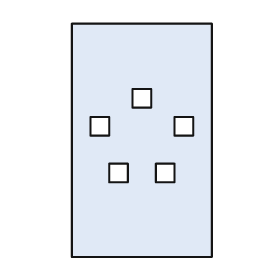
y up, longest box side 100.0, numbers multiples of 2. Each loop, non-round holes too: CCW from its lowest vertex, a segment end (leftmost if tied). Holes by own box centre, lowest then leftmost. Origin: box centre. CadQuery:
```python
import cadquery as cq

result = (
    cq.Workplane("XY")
    .moveTo(-30.0, -50.0)
    .lineTo(30.0, -50.0)
    .lineTo(30.0, 50.0)
    .lineTo(-30.0, 50.0)
    .close()
    .moveTo(-14.0, -18.0)
    .lineTo(-6.0, -18.0)
    .lineTo(-6.0, -10.0)
    .lineTo(-14.0, -10.0)
    .close()
    .moveTo(6.0, -18.0)
    .lineTo(14.0, -18.0)
    .lineTo(14.0, -10.0)
    .lineTo(6.0, -10.0)
    .close()
    .moveTo(-22.0, 2.0)
    .lineTo(-14.0, 2.0)
    .lineTo(-14.0, 10.0)
    .lineTo(-22.0, 10.0)
    .close()
    .moveTo(14.0, 2.0)
    .lineTo(22.0, 2.0)
    .lineTo(22.0, 10.0)
    .lineTo(14.0, 10.0)
    .close()
    .moveTo(-4.0, 14.0)
    .lineTo(4.0, 14.0)
    .lineTo(4.0, 22.0)
    .lineTo(-4.0, 22.0)
    .close()
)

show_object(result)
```